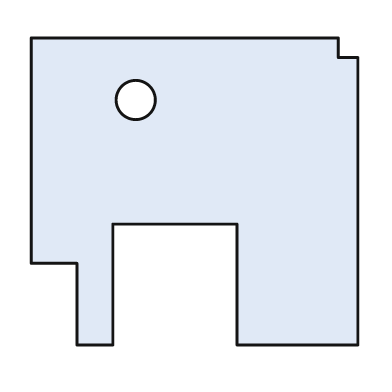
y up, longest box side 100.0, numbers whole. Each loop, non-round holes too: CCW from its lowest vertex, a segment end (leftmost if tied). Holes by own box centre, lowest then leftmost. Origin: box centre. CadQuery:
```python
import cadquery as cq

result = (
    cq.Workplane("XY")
    .moveTo(-36.0, -47.0)
    .lineTo(-25.0, -47.0)
    .lineTo(-25.0, -10.0)
    .lineTo(13.0, -10.0)
    .lineTo(13.0, -47.0)
    .lineTo(50.0, -47.0)
    .lineTo(50.0, 41.0)
    .lineTo(44.0, 41.0)
    .lineTo(44.0, 47.0)
    .lineTo(-50.0, 47.0)
    .lineTo(-50.0, -22.0)
    .lineTo(-36.0, -22.0)
    .close()
    .moveTo(-18.0, 28.0)
    .circle(6.0)
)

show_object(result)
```